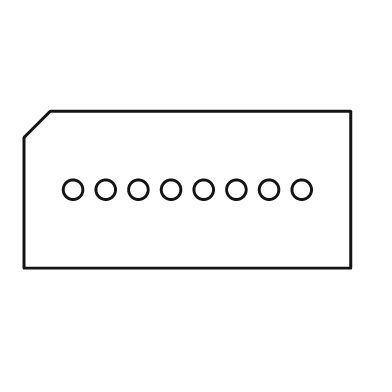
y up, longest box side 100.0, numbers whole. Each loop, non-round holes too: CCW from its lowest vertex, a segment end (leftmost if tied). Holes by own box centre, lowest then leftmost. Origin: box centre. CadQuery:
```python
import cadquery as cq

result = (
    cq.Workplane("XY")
    .moveTo(-50.0, -24.0)
    .lineTo(50.0, -24.0)
    .lineTo(50.0, 24.0)
    .lineTo(-42.0, 24.0)
    .lineTo(-50.0, 16.0)
    .close()
    .moveTo(-35.0, 0.0)
    .circle(3.0)
    .moveTo(-25.0, 0.0)
    .circle(3.0)
    .moveTo(-15.0, 0.0)
    .circle(3.0)
    .moveTo(-5.0, 0.0)
    .circle(3.0)
    .moveTo(5.0, 0.0)
    .circle(3.0)
    .moveTo(15.0, 0.0)
    .circle(3.0)
    .moveTo(25.0, 0.0)
    .circle(3.0)
    .moveTo(35.0, 0.0)
    .circle(3.0)
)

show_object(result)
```